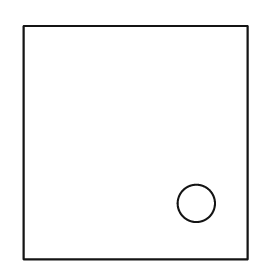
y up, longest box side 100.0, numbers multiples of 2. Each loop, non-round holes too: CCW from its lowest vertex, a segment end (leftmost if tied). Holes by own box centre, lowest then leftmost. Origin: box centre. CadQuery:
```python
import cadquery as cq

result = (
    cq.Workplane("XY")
    .moveTo(-48.0, -50.0)
    .lineTo(48.0, -50.0)
    .lineTo(48.0, 50.0)
    .lineTo(-48.0, 50.0)
    .close()
    .moveTo(26.0, -26.0)
    .circle(8.0)
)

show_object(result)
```